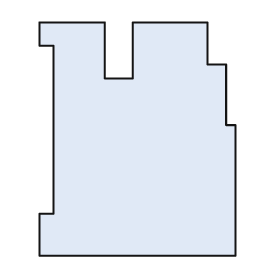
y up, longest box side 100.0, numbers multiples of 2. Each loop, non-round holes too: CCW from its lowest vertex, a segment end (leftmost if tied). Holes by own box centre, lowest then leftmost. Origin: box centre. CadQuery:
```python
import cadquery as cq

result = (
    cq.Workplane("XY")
    .moveTo(-42.0, -50.0)
    .lineTo(42.0, -50.0)
    .lineTo(42.0, 6.0)
    .lineTo(38.0, 6.0)
    .lineTo(38.0, 32.0)
    .lineTo(30.0, 32.0)
    .lineTo(30.0, 50.0)
    .lineTo(-2.0, 50.0)
    .lineTo(-2.0, 26.0)
    .lineTo(-14.0, 26.0)
    .lineTo(-14.0, 50.0)
    .lineTo(-42.0, 50.0)
    .lineTo(-42.0, 40.0)
    .lineTo(-36.0, 40.0)
    .lineTo(-36.0, -32.0)
    .lineTo(-42.0, -32.0)
    .close()
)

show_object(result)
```